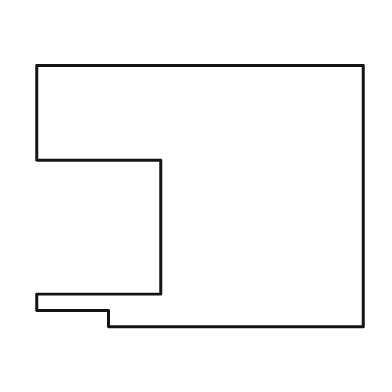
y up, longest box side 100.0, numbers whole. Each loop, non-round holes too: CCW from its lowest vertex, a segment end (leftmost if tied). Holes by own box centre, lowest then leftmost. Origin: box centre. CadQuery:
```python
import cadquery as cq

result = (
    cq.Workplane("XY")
    .moveTo(-28.0, -40.0)
    .lineTo(50.0, -40.0)
    .lineTo(50.0, 40.0)
    .lineTo(-50.0, 40.0)
    .lineTo(-50.0, 11.0)
    .lineTo(-12.0, 11.0)
    .lineTo(-12.0, -30.0)
    .lineTo(-50.0, -30.0)
    .lineTo(-50.0, -35.0)
    .lineTo(-28.0, -35.0)
    .close()
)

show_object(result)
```